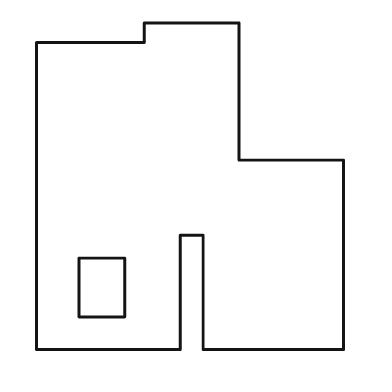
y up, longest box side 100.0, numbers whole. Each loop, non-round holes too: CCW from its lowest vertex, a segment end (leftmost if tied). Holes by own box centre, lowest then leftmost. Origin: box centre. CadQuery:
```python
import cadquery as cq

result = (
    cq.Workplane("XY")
    .moveTo(-47.0, -50.0)
    .lineTo(-3.0, -50.0)
    .lineTo(-3.0, -15.0)
    .lineTo(4.0, -15.0)
    .lineTo(4.0, -50.0)
    .lineTo(47.0, -50.0)
    .lineTo(47.0, 8.0)
    .lineTo(15.0, 8.0)
    .lineTo(15.0, 50.0)
    .lineTo(-14.0, 50.0)
    .lineTo(-14.0, 44.0)
    .lineTo(-47.0, 44.0)
    .close()
    .moveTo(-34.0, -40.0)
    .lineTo(-20.0, -40.0)
    .lineTo(-20.0, -22.0)
    .lineTo(-34.0, -22.0)
    .close()
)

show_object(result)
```